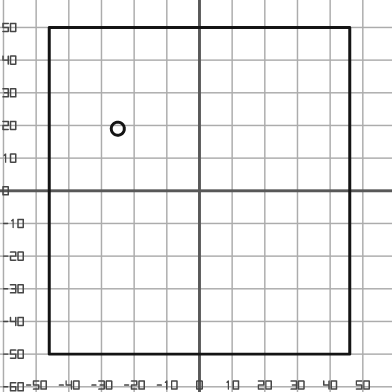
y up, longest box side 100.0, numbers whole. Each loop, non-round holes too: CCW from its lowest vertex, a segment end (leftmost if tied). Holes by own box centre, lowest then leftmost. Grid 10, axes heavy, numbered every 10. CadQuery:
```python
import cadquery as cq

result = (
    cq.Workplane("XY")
    .moveTo(-46.0, -50.0)
    .lineTo(46.0, -50.0)
    .lineTo(46.0, 50.0)
    .lineTo(-46.0, 50.0)
    .close()
    .moveTo(-25.0, 19.0)
    .circle(2.0)
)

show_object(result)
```